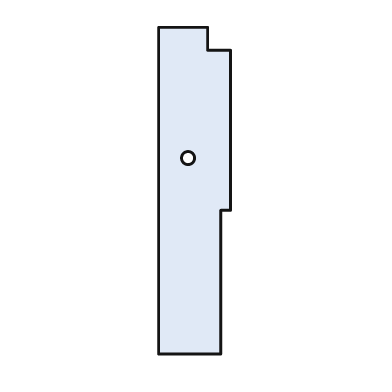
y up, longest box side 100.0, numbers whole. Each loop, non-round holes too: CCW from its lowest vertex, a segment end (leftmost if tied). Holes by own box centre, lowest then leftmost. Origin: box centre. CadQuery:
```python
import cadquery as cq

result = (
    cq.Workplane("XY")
    .moveTo(-11.0, -50.0)
    .lineTo(8.0, -50.0)
    .lineTo(8.0, -6.0)
    .lineTo(11.0, -6.0)
    .lineTo(11.0, 43.0)
    .lineTo(4.0, 43.0)
    .lineTo(4.0, 50.0)
    .lineTo(-11.0, 50.0)
    .close()
    .moveTo(-2.0, 10.0)
    .circle(2.0)
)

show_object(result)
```